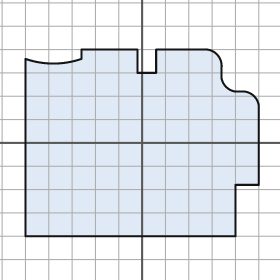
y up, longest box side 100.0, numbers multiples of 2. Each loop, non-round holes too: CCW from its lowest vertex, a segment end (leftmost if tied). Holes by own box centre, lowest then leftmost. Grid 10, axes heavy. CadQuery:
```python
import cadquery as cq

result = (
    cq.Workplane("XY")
    .moveTo(-50.0, -40.0)
    .lineTo(40.0, -40.0)
    .lineTo(40.0, -18.0)
    .lineTo(50.0, -18.0)
    .lineTo(50.0, 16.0)
    .threePointArc((48.0, 20.0), (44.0, 22.0))
    .lineTo(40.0, 22.0)
    .threePointArc((36.0, 24.0), (34.0, 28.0))
    .lineTo(34.0, 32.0)
    .threePointArc((32.0, 38.0), (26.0, 40.0))
    .lineTo(6.0, 40.0)
    .lineTo(6.0, 30.0)
    .lineTo(-2.0, 30.0)
    .lineTo(-2.0, 40.0)
    .lineTo(-26.0, 40.0)
    .lineTo(-26.0, 36.0)
    .threePointArc((-38.0, 34.0), (-50.0, 36.0))
    .close()
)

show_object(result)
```